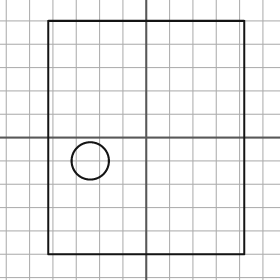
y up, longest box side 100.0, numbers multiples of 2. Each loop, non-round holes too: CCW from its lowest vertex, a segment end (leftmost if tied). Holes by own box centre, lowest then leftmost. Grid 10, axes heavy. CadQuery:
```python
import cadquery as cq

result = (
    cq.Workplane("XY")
    .moveTo(-42.0, -50.0)
    .lineTo(42.0, -50.0)
    .lineTo(42.0, 50.0)
    .lineTo(-42.0, 50.0)
    .close()
    .moveTo(-24.0, -10.0)
    .circle(8.0)
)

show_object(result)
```